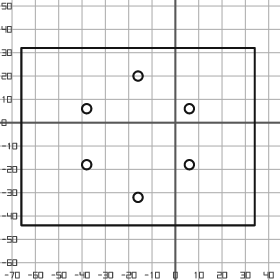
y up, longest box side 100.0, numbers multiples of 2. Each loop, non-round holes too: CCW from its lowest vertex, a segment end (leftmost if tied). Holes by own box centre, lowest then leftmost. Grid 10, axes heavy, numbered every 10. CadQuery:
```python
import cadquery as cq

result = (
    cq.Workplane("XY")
    .moveTo(-66.0, -44.0)
    .lineTo(34.0, -44.0)
    .lineTo(34.0, 32.0)
    .lineTo(-66.0, 32.0)
    .close()
    .moveTo(-16.0, -32.0)
    .circle(2.0)
    .moveTo(-38.0, -18.0)
    .circle(2.0)
    .moveTo(6.0, -18.0)
    .circle(2.0)
    .moveTo(-38.0, 6.0)
    .circle(2.0)
    .moveTo(6.0, 6.0)
    .circle(2.0)
    .moveTo(-16.0, 20.0)
    .circle(2.0)
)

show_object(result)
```